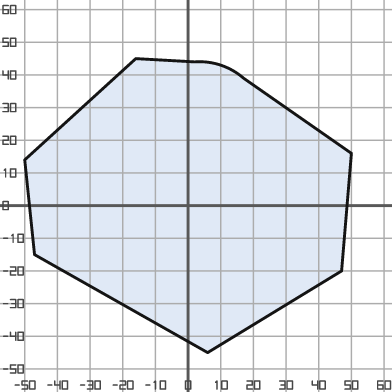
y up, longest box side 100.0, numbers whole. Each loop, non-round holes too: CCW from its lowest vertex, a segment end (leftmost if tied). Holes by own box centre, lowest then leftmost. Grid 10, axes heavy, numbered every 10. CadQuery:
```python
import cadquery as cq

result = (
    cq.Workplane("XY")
    .moveTo(6.0, -45.0)
    .lineTo(47.0, -20.0)
    .lineTo(50.0, 16.0)
    .lineTo(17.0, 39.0)
    .threePointArc((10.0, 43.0), (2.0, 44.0))
    .lineTo(-16.0, 45.0)
    .lineTo(-50.0, 14.0)
    .lineTo(-47.0, -15.0)
    .close()
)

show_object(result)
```